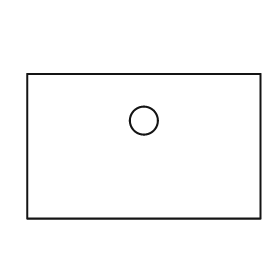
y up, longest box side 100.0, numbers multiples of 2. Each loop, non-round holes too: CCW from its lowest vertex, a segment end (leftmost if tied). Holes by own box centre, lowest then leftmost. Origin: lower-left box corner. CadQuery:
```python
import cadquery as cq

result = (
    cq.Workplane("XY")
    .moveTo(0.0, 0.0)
    .lineTo(100.0, 0.0)
    .lineTo(100.0, 62.0)
    .lineTo(0.0, 62.0)
    .close()
    .moveTo(50.0, 42.0)
    .circle(6.0)
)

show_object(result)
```